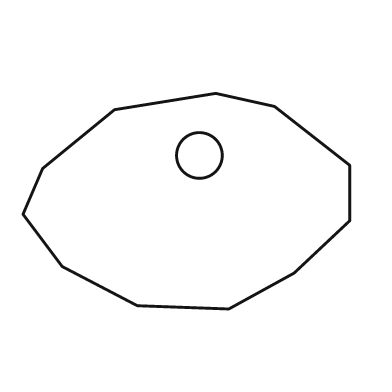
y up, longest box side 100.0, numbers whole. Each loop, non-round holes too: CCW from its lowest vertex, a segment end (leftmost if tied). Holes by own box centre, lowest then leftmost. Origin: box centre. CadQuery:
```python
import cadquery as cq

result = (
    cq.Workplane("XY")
    .moveTo(13.0, -33.0)
    .lineTo(33.0, -22.0)
    .lineTo(50.0, -6.0)
    .lineTo(50.0, 11.0)
    .lineTo(27.0, 29.0)
    .lineTo(9.0, 33.0)
    .lineTo(-22.0, 28.0)
    .lineTo(-44.0, 10.0)
    .lineTo(-50.0, -4.0)
    .lineTo(-38.0, -20.0)
    .lineTo(-15.0, -32.0)
    .close()
    .moveTo(4.0, 14.0)
    .circle(7.0)
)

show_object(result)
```